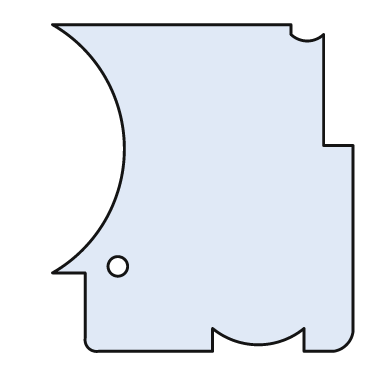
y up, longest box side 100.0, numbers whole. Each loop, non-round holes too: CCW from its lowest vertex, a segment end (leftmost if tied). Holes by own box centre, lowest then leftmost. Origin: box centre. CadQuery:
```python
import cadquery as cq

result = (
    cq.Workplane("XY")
    .moveTo(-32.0, -50.0)
    .lineTo(3.0, -50.0)
    .lineTo(3.0, -43.0)
    .threePointArc((17.0, -48.0), (31.0, -43.0))
    .lineTo(31.0, -50.0)
    .lineTo(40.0, -50.0)
    .threePointArc((44.0, -48.0), (46.0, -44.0))
    .lineTo(46.0, 13.0)
    .lineTo(37.0, 13.0)
    .lineTo(37.0, 47.0)
    .threePointArc((32.0, 45.0), (27.0, 47.0))
    .lineTo(27.0, 50.0)
    .lineTo(-46.0, 50.0)
    .threePointArc((-24.0, 12.0), (-46.0, -26.0))
    .lineTo(-36.0, -26.0)
    .lineTo(-36.0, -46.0)
    .threePointArc((-35.0, -49.0), (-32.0, -50.0))
    .close()
    .moveTo(-26.0, -24.0)
    .circle(3.0)
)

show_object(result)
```